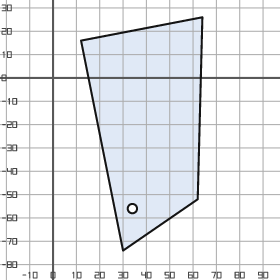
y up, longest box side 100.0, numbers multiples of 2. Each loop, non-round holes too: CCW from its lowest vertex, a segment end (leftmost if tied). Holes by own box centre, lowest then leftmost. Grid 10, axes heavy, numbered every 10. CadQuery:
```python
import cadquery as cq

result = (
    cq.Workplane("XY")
    .moveTo(30.0, -74.0)
    .lineTo(62.0, -52.0)
    .lineTo(64.0, 26.0)
    .lineTo(12.0, 16.0)
    .close()
    .moveTo(34.0, -56.0)
    .circle(2.0)
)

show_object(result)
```